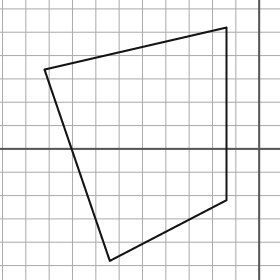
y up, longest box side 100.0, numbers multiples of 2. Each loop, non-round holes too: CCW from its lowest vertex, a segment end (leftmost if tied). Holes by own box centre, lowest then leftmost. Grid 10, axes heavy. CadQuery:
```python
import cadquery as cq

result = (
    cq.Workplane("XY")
    .moveTo(-64.0, -48.0)
    .lineTo(-14.0, -22.0)
    .lineTo(-14.0, 52.0)
    .lineTo(-92.0, 34.0)
    .close()
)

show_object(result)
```